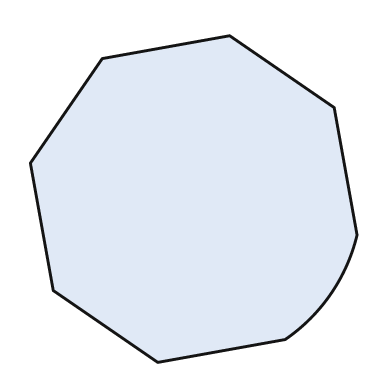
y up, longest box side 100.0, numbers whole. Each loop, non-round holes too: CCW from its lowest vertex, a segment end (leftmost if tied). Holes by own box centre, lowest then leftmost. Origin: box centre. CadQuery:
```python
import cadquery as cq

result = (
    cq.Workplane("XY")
    .moveTo(-11.0, -50.0)
    .lineTo(28.0, -43.0)
    .threePointArc((42.0, -29.0), (50.0, -11.0))
    .lineTo(43.0, 28.0)
    .lineTo(11.0, 50.0)
    .lineTo(-28.0, 43.0)
    .lineTo(-50.0, 11.0)
    .lineTo(-43.0, -28.0)
    .close()
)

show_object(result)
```